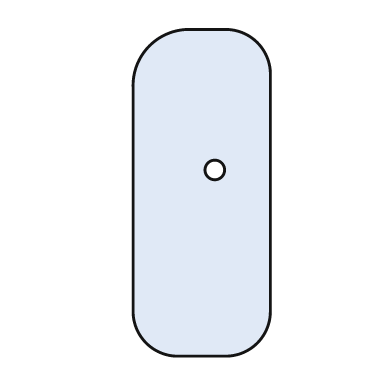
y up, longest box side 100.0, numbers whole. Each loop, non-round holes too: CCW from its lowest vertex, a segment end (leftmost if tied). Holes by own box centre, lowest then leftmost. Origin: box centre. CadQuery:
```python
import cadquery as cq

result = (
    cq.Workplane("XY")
    .moveTo(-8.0, -50.0)
    .lineTo(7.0, -50.0)
    .threePointArc((17.0, -46.0), (21.0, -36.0))
    .lineTo(21.0, 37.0)
    .threePointArc((17.0, 46.0), (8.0, 50.0))
    .lineTo(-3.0, 50.0)
    .threePointArc((-16.0, 45.0), (-21.0, 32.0))
    .lineTo(-21.0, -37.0)
    .threePointArc((-17.0, -46.0), (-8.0, -50.0))
    .close()
    .moveTo(4.0, 7.0)
    .circle(3.0)
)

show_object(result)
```